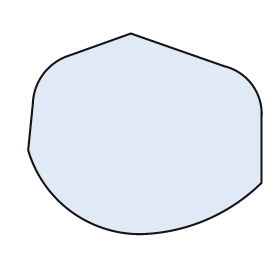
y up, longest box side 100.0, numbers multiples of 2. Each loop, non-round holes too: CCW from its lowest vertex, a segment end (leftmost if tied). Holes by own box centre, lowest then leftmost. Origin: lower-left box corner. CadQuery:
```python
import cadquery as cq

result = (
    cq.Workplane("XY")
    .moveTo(48.0, 0.0)
    .threePointArc((76.0, 6.0), (100.0, 22.0))
    .lineTo(100.0, 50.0)
    .threePointArc((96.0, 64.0), (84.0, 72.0))
    .lineTo(44.0, 86.0)
    .lineTo(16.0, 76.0)
    .threePointArc((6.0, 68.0), (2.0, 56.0))
    .lineTo(0.0, 36.0)
    .threePointArc((18.0, 10.0), (48.0, 0.0))
    .close()
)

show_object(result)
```